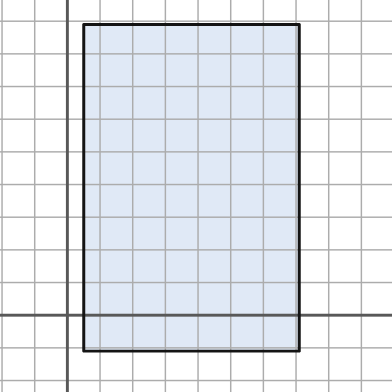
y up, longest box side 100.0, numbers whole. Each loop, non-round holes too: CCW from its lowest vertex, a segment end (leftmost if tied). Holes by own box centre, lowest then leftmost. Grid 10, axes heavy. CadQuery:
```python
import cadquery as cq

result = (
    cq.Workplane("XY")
    .moveTo(5.0, -11.0)
    .lineTo(71.0, -11.0)
    .lineTo(71.0, 89.0)
    .lineTo(5.0, 89.0)
    .close()
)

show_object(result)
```